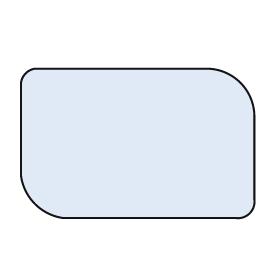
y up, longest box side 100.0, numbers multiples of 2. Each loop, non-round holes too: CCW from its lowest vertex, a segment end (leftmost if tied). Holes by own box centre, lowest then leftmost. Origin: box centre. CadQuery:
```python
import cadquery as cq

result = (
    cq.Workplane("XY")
    .moveTo(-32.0, -32.0)
    .lineTo(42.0, -32.0)
    .threePointArc((48.0, -30.0), (50.0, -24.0))
    .lineTo(50.0, 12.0)
    .threePointArc((44.0, 26.0), (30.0, 32.0))
    .lineTo(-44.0, 32.0)
    .threePointArc((-48.0, 30.0), (-50.0, 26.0))
    .lineTo(-50.0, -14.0)
    .threePointArc((-44.0, -26.0), (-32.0, -32.0))
    .close()
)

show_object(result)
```